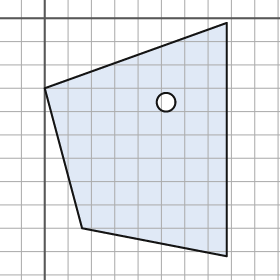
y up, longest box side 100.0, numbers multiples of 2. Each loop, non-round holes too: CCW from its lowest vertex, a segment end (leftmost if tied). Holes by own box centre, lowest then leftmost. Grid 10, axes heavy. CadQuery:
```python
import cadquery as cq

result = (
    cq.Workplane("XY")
    .moveTo(78.0, -102.0)
    .lineTo(78.0, -2.0)
    .lineTo(0.0, -30.0)
    .lineTo(16.0, -90.0)
    .close()
    .moveTo(52.0, -36.0)
    .circle(4.0)
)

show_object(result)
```